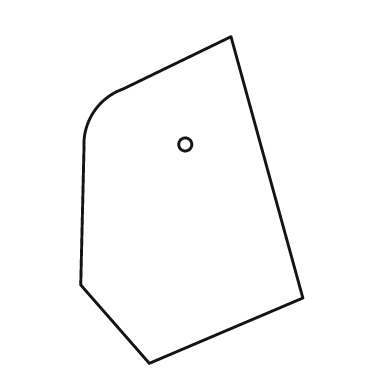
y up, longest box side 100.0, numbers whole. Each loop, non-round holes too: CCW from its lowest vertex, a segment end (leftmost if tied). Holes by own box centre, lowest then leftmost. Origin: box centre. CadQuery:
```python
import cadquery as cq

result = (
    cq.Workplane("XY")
    .moveTo(-13.0, -50.0)
    .lineTo(34.0, -30.0)
    .lineTo(12.0, 50.0)
    .lineTo(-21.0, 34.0)
    .threePointArc((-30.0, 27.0), (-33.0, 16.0))
    .lineTo(-34.0, -26.0)
    .close()
    .moveTo(-2.0, 17.0)
    .circle(2.0)
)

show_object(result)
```